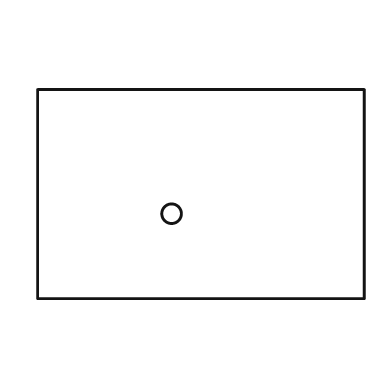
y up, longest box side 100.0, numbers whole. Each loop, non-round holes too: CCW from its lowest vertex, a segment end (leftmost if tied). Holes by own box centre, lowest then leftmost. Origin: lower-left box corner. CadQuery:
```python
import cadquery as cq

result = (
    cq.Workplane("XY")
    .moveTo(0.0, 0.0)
    .lineTo(100.0, 0.0)
    .lineTo(100.0, 64.0)
    .lineTo(0.0, 64.0)
    .close()
    .moveTo(41.0, 26.0)
    .circle(3.0)
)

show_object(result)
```